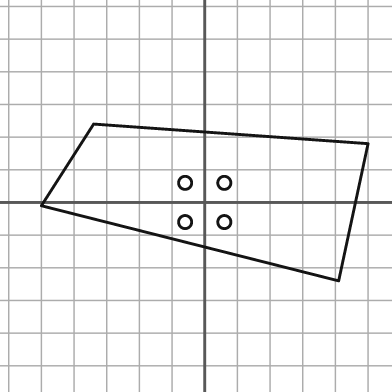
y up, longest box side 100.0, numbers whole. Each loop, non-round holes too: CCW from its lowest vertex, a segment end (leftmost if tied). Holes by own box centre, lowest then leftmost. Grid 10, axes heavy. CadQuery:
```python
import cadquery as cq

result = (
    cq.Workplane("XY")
    .moveTo(41.0, -24.0)
    .lineTo(50.0, 18.0)
    .lineTo(-34.0, 24.0)
    .lineTo(-50.0, -1.0)
    .close()
    .moveTo(-6.0, -6.0)
    .circle(2.0)
    .moveTo(6.0, -6.0)
    .circle(2.0)
    .moveTo(-6.0, 6.0)
    .circle(2.0)
    .moveTo(6.0, 6.0)
    .circle(2.0)
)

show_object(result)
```